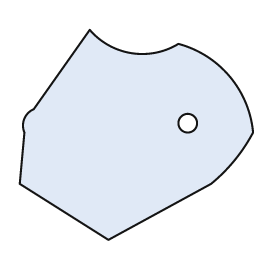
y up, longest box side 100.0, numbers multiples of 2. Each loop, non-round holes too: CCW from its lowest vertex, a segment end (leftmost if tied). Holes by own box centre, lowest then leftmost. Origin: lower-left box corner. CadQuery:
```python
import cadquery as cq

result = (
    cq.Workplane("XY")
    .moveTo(38.0, 0.0)
    .lineTo(82.0, 24.0)
    .threePointArc((92.0, 34.0), (100.0, 46.0))
    .threePointArc((90.0, 70.0), (68.0, 84.0))
    .threePointArc((48.0, 80.0), (30.0, 90.0))
    .lineTo(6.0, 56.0)
    .threePointArc((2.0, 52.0), (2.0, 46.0))
    .lineTo(0.0, 24.0)
    .close()
    .moveTo(72.0, 50.0)
    .circle(4.0)
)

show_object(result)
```